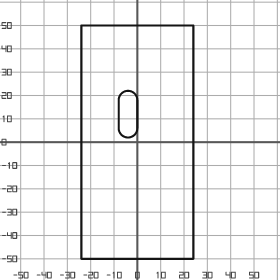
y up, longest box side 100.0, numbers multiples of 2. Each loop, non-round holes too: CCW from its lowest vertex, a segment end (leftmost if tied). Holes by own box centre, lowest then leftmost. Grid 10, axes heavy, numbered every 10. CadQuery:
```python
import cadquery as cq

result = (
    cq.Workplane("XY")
    .moveTo(-24.0, -50.0)
    .lineTo(24.0, -50.0)
    .lineTo(24.0, 50.0)
    .lineTo(-24.0, 50.0)
    .close()
    .moveTo(-8.0, 6.0)
    .threePointArc((-4.0, 2.0), (0.0, 6.0))
    .lineTo(0.0, 18.0)
    .threePointArc((-4.0, 22.0), (-8.0, 18.0))
    .close()
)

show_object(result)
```